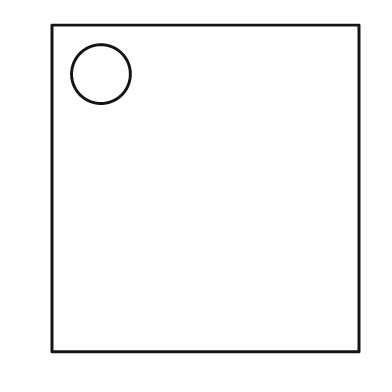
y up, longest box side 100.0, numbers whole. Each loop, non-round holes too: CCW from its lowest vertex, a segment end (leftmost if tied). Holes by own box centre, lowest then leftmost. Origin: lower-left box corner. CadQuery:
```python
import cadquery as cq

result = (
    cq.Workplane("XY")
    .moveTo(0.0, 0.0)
    .lineTo(94.0, 0.0)
    .lineTo(94.0, 100.0)
    .lineTo(0.0, 100.0)
    .close()
    .moveTo(15.0, 85.0)
    .circle(9.0)
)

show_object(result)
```